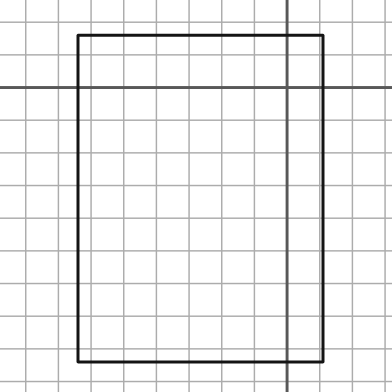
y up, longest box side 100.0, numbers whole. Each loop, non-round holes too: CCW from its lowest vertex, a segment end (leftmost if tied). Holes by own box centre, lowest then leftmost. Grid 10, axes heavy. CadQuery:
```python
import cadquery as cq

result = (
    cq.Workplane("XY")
    .moveTo(-64.0, -84.0)
    .lineTo(11.0, -84.0)
    .lineTo(11.0, 16.0)
    .lineTo(-64.0, 16.0)
    .close()
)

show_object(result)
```